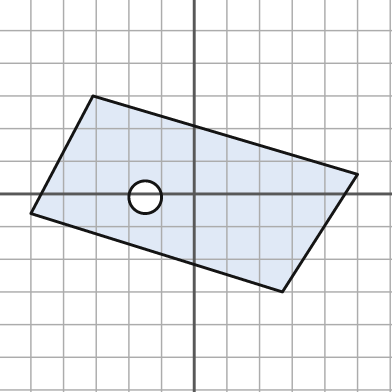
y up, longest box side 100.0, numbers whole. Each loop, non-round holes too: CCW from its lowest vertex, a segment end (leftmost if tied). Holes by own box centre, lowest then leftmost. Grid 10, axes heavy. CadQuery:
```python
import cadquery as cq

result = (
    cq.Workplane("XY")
    .moveTo(27.0, -30.0)
    .lineTo(50.0, 6.0)
    .lineTo(-31.0, 30.0)
    .lineTo(-50.0, -6.0)
    .close()
    .moveTo(-15.0, -1.0)
    .circle(5.0)
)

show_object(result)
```